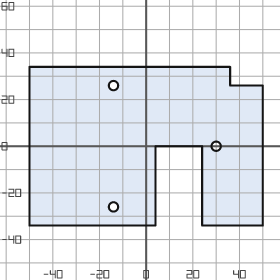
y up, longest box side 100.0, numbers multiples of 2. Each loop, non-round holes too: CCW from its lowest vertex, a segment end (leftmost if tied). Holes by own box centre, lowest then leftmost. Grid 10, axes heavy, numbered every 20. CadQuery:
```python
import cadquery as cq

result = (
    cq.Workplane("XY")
    .moveTo(-50.0, -34.0)
    .lineTo(4.0, -34.0)
    .lineTo(4.0, 0.0)
    .lineTo(24.0, 0.0)
    .lineTo(24.0, -34.0)
    .lineTo(50.0, -34.0)
    .lineTo(50.0, 26.0)
    .lineTo(36.0, 26.0)
    .lineTo(36.0, 34.0)
    .lineTo(-50.0, 34.0)
    .close()
    .moveTo(-14.0, -26.0)
    .circle(2.0)
    .moveTo(30.0, 0.0)
    .circle(2.0)
    .moveTo(-14.0, 26.0)
    .circle(2.0)
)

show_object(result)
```